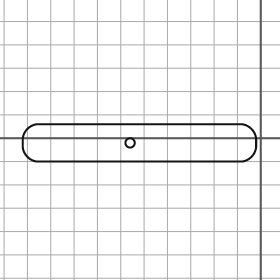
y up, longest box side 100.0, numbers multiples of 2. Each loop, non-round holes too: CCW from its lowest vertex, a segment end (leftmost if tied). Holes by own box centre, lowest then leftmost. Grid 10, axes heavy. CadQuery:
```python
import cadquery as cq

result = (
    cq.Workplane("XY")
    .moveTo(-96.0, -10.0)
    .lineTo(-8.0, -10.0)
    .threePointArc((-4.0, -8.0), (-2.0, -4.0))
    .lineTo(-2.0, 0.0)
    .threePointArc((-4.0, 4.0), (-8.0, 6.0))
    .lineTo(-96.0, 6.0)
    .threePointArc((-100.0, 4.0), (-102.0, 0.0))
    .lineTo(-102.0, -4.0)
    .threePointArc((-100.0, -8.0), (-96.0, -10.0))
    .close()
    .moveTo(-56.0, -2.0)
    .circle(2.0)
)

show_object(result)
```